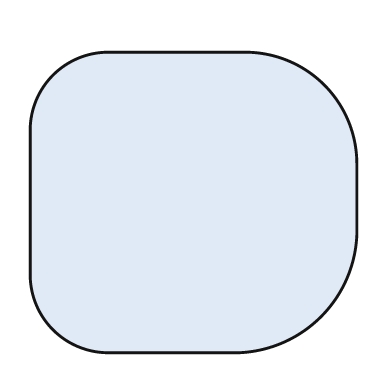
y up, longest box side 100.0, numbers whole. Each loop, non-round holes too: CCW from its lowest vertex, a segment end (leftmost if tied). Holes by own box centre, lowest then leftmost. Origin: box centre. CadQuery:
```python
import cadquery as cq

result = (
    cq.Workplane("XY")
    .moveTo(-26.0, -46.0)
    .lineTo(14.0, -46.0)
    .threePointArc((39.0, -35.0), (50.0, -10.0))
    .lineTo(50.0, 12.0)
    .threePointArc((40.0, 36.0), (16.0, 46.0))
    .lineTo(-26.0, 46.0)
    .threePointArc((-43.0, 39.0), (-50.0, 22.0))
    .lineTo(-50.0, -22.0)
    .threePointArc((-43.0, -39.0), (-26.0, -46.0))
    .close()
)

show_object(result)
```